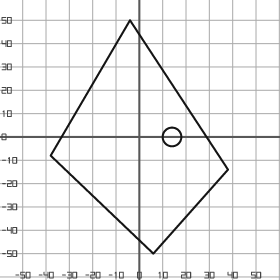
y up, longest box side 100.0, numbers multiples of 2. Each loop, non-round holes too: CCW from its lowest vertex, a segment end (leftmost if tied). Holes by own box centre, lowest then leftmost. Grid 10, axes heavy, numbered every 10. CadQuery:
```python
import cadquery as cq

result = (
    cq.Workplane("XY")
    .moveTo(6.0, -50.0)
    .lineTo(38.0, -14.0)
    .lineTo(-4.0, 50.0)
    .lineTo(-38.0, -8.0)
    .close()
    .moveTo(14.0, 0.0)
    .circle(4.0)
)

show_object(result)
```